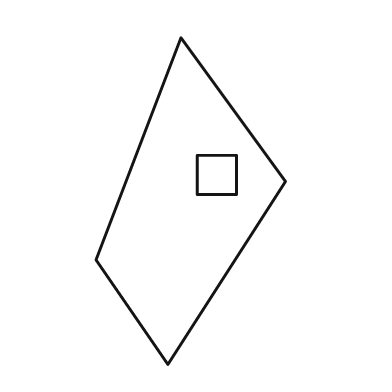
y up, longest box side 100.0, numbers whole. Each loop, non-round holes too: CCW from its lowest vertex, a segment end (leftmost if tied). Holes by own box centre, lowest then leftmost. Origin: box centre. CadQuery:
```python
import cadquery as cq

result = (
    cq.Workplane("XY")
    .moveTo(-7.0, -50.0)
    .lineTo(29.0, 6.0)
    .lineTo(-3.0, 50.0)
    .lineTo(-29.0, -18.0)
    .close()
    .moveTo(2.0, 2.0)
    .lineTo(14.0, 2.0)
    .lineTo(14.0, 14.0)
    .lineTo(2.0, 14.0)
    .close()
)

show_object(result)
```